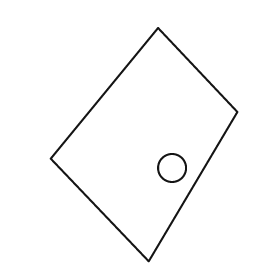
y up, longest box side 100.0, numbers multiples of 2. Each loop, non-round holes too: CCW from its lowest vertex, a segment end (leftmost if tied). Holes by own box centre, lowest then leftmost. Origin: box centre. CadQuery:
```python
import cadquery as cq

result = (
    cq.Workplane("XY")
    .moveTo(2.0, -50.0)
    .lineTo(40.0, 14.0)
    .lineTo(6.0, 50.0)
    .lineTo(-40.0, -6.0)
    .close()
    .moveTo(12.0, -10.0)
    .circle(6.0)
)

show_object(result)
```